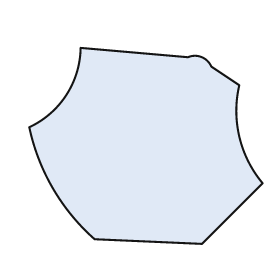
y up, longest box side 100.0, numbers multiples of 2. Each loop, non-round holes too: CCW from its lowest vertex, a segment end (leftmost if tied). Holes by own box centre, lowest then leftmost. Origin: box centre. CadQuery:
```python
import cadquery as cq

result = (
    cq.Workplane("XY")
    .moveTo(24.0, -42.0)
    .lineTo(50.0, -16.0)
    .threePointArc((40.0, 4.0), (40.0, 26.0))
    .lineTo(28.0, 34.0)
    .threePointArc((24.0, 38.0), (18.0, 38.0))
    .lineTo(-28.0, 42.0)
    .threePointArc((-34.0, 22.0), (-50.0, 8.0))
    .threePointArc((-40.0, -18.0), (-22.0, -40.0))
    .close()
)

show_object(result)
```